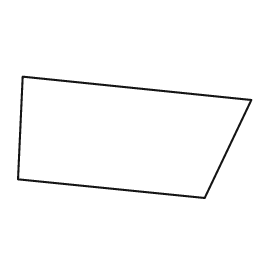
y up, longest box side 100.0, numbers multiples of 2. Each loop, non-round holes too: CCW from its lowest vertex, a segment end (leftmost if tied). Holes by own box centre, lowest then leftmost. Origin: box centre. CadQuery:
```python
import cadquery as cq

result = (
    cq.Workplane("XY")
    .moveTo(30.0, -26.0)
    .lineTo(50.0, 16.0)
    .lineTo(-48.0, 26.0)
    .lineTo(-50.0, -18.0)
    .close()
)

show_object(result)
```